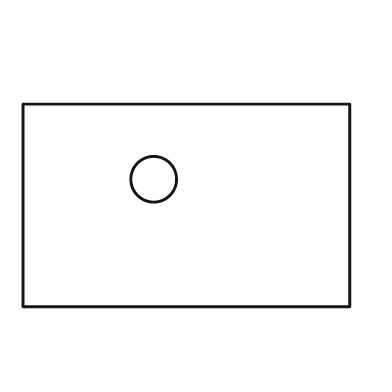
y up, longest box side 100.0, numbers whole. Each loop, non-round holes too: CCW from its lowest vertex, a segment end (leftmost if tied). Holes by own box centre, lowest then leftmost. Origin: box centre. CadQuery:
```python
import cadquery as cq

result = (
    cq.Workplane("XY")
    .moveTo(-50.0, -31.0)
    .lineTo(50.0, -31.0)
    .lineTo(50.0, 31.0)
    .lineTo(-50.0, 31.0)
    .close()
    .moveTo(-10.0, 8.0)
    .circle(7.0)
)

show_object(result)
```